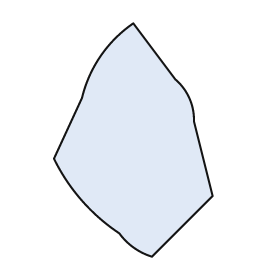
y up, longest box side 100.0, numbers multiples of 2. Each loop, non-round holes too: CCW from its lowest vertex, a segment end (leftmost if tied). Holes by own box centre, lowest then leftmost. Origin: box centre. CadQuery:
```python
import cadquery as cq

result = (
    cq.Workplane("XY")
    .moveTo(8.0, -50.0)
    .lineTo(34.0, -24.0)
    .lineTo(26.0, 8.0)
    .threePointArc((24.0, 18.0), (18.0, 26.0))
    .lineTo(0.0, 50.0)
    .threePointArc((-14.0, 36.0), (-22.0, 18.0))
    .lineTo(-34.0, -8.0)
    .threePointArc((-22.0, -26.0), (-6.0, -40.0))
    .threePointArc((0.0, -46.0), (8.0, -50.0))
    .close()
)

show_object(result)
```